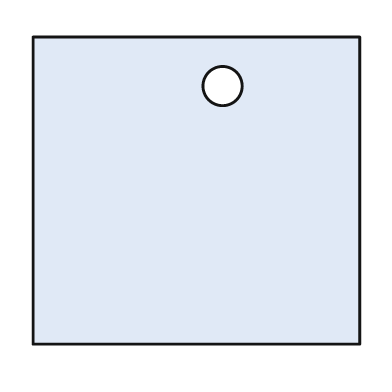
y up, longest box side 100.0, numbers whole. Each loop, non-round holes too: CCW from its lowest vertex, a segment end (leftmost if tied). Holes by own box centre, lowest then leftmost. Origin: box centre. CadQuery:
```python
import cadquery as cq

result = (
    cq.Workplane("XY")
    .moveTo(-50.0, -47.0)
    .lineTo(50.0, -47.0)
    .lineTo(50.0, 47.0)
    .lineTo(-50.0, 47.0)
    .close()
    .moveTo(8.0, 32.0)
    .circle(6.0)
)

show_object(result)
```